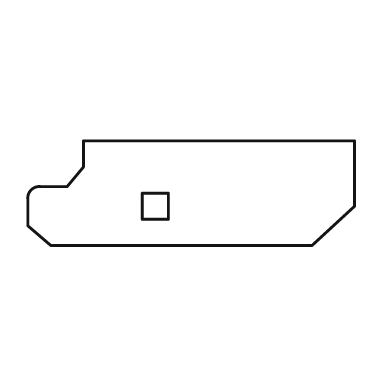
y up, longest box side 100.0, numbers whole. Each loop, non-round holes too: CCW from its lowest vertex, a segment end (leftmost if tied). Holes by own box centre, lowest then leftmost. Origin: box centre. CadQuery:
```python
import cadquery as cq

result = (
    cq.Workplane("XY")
    .moveTo(-43.0, -16.0)
    .lineTo(37.0, -16.0)
    .lineTo(50.0, -4.0)
    .lineTo(50.0, 16.0)
    .lineTo(-33.0, 16.0)
    .lineTo(-33.0, 8.0)
    .lineTo(-38.0, 2.0)
    .lineTo(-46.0, 2.0)
    .threePointArc((-49.0, 1.0), (-50.0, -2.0))
    .lineTo(-50.0, -10.0)
    .close()
    .moveTo(-15.0, -8.0)
    .lineTo(-7.0, -8.0)
    .lineTo(-7.0, 0.0)
    .lineTo(-15.0, 0.0)
    .close()
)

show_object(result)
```